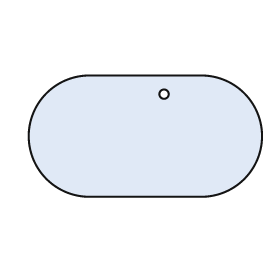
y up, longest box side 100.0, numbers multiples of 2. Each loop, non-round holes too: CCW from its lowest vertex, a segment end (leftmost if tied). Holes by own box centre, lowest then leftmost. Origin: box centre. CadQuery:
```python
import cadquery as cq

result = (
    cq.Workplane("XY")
    .moveTo(-24.0, -26.0)
    .lineTo(24.0, -26.0)
    .threePointArc((50.0, 0.0), (24.0, 26.0))
    .lineTo(-24.0, 26.0)
    .threePointArc((-50.0, 0.0), (-24.0, -26.0))
    .close()
    .moveTo(8.0, 18.0)
    .circle(2.0)
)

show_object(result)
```